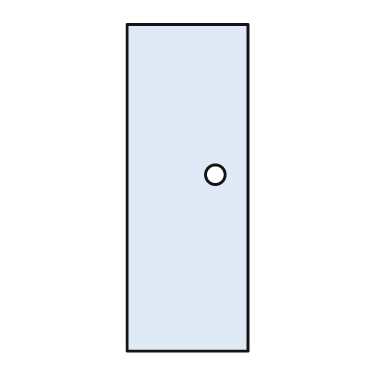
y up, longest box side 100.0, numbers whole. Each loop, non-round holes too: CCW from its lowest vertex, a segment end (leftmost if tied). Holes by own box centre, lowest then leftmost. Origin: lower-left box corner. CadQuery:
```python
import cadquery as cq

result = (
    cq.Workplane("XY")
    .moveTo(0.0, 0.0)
    .lineTo(37.0, 0.0)
    .lineTo(37.0, 100.0)
    .lineTo(0.0, 100.0)
    .close()
    .moveTo(27.0, 54.0)
    .circle(3.0)
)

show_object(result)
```